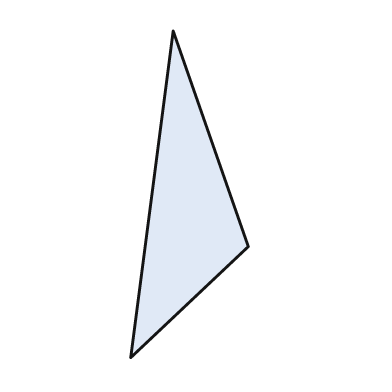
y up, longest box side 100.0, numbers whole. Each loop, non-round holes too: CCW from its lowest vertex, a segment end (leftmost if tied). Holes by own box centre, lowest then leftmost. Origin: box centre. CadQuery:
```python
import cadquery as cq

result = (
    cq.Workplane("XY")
    .moveTo(-18.0, -50.0)
    .lineTo(18.0, -16.0)
    .lineTo(-5.0, 50.0)
    .close()
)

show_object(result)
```